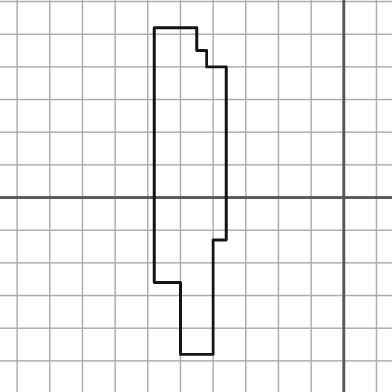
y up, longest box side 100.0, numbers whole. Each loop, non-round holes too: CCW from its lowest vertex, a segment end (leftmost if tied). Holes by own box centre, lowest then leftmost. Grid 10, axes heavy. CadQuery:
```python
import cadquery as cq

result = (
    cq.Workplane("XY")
    .moveTo(-50.0, -48.0)
    .lineTo(-40.0, -48.0)
    .lineTo(-40.0, -13.0)
    .lineTo(-36.0, -13.0)
    .lineTo(-36.0, 40.0)
    .lineTo(-42.0, 40.0)
    .lineTo(-42.0, 45.0)
    .lineTo(-45.0, 45.0)
    .lineTo(-45.0, 52.0)
    .lineTo(-58.0, 52.0)
    .lineTo(-58.0, -26.0)
    .lineTo(-50.0, -26.0)
    .close()
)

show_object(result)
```